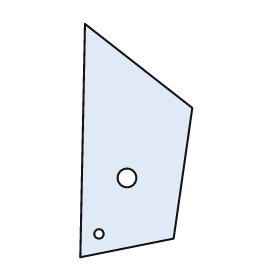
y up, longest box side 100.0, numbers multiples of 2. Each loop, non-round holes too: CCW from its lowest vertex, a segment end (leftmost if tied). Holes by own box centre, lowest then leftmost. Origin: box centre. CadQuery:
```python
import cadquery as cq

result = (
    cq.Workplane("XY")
    .moveTo(-24.0, -50.0)
    .lineTo(16.0, -42.0)
    .lineTo(24.0, 14.0)
    .lineTo(-22.0, 50.0)
    .close()
    .moveTo(-16.0, -40.0)
    .circle(2.0)
    .moveTo(-4.0, -16.0)
    .circle(4.0)
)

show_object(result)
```